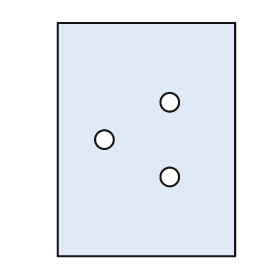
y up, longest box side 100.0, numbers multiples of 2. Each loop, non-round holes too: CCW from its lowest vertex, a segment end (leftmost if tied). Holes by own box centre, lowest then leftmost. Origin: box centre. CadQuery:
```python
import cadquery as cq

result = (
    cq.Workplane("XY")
    .moveTo(-38.0, -50.0)
    .lineTo(38.0, -50.0)
    .lineTo(38.0, 50.0)
    .lineTo(-38.0, 50.0)
    .close()
    .moveTo(10.0, -16.0)
    .circle(4.0)
    .moveTo(-18.0, 0.0)
    .circle(4.0)
    .moveTo(10.0, 16.0)
    .circle(4.0)
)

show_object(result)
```